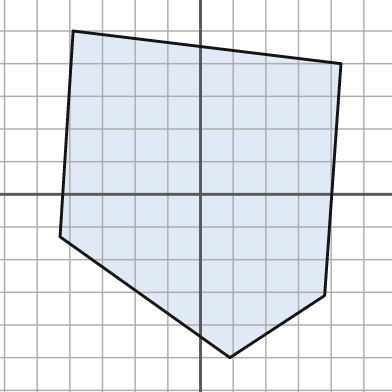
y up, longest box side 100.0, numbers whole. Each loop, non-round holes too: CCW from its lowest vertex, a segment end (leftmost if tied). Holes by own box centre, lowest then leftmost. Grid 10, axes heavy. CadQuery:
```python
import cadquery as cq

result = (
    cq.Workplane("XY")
    .moveTo(9.0, -50.0)
    .lineTo(38.0, -31.0)
    .lineTo(43.0, 40.0)
    .lineTo(-39.0, 50.0)
    .lineTo(-43.0, -13.0)
    .close()
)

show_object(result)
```